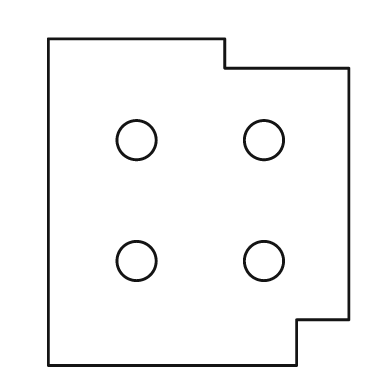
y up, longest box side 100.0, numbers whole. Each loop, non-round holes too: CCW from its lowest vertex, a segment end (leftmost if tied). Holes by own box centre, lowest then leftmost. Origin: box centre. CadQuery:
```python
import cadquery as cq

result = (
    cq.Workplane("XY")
    .moveTo(-46.0, -50.0)
    .lineTo(30.0, -50.0)
    .lineTo(30.0, -36.0)
    .lineTo(46.0, -36.0)
    .lineTo(46.0, 41.0)
    .lineTo(8.0, 41.0)
    .lineTo(8.0, 50.0)
    .lineTo(-46.0, 50.0)
    .close()
    .moveTo(-19.0, -18.0)
    .circle(6.0)
    .moveTo(20.0, -18.0)
    .circle(6.0)
    .moveTo(-19.0, 19.0)
    .circle(6.0)
    .moveTo(20.0, 19.0)
    .circle(6.0)
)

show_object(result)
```